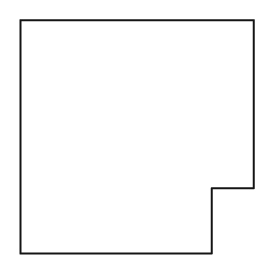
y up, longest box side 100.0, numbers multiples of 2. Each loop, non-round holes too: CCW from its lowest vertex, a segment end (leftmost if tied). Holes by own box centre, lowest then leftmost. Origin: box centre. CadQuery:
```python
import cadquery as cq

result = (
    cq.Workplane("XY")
    .moveTo(-50.0, -50.0)
    .lineTo(32.0, -50.0)
    .lineTo(32.0, -22.0)
    .lineTo(50.0, -22.0)
    .lineTo(50.0, 50.0)
    .lineTo(-50.0, 50.0)
    .close()
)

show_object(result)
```